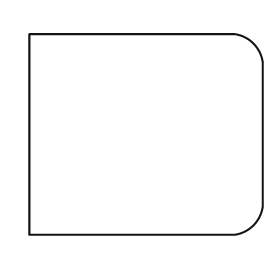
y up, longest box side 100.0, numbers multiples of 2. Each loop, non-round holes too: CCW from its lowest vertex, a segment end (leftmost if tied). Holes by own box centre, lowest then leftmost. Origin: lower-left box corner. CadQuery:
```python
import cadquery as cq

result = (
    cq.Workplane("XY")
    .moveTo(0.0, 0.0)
    .lineTo(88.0, 0.0)
    .threePointArc((96.0, 4.0), (100.0, 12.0))
    .lineTo(100.0, 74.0)
    .threePointArc((96.0, 82.0), (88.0, 86.0))
    .lineTo(0.0, 86.0)
    .close()
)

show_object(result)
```